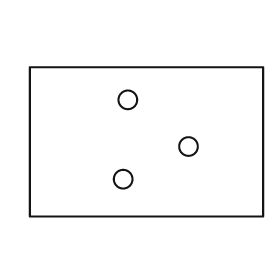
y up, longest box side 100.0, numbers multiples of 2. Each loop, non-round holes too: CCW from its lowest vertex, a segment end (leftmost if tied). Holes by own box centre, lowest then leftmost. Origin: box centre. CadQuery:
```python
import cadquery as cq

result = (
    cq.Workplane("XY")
    .moveTo(-50.0, -32.0)
    .lineTo(50.0, -32.0)
    .lineTo(50.0, 32.0)
    .lineTo(-50.0, 32.0)
    .close()
    .moveTo(-10.0, -16.0)
    .circle(4.0)
    .moveTo(18.0, -2.0)
    .circle(4.0)
    .moveTo(-8.0, 18.0)
    .circle(4.0)
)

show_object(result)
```